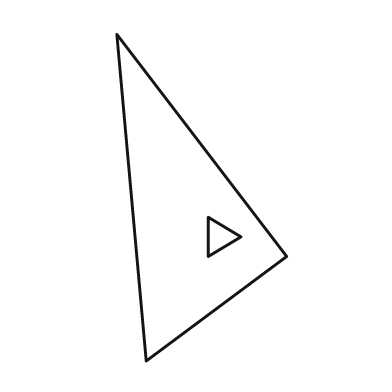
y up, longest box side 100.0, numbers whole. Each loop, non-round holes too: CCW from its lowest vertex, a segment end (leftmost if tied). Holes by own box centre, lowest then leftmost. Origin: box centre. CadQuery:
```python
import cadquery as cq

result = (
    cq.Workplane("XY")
    .moveTo(-17.0, -50.0)
    .lineTo(26.0, -18.0)
    .lineTo(-26.0, 50.0)
    .close()
    .moveTo(2.0, -18.0)
    .lineTo(12.0, -12.0)
    .lineTo(2.0, -6.0)
    .close()
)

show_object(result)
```